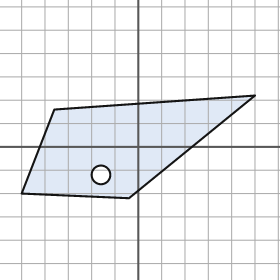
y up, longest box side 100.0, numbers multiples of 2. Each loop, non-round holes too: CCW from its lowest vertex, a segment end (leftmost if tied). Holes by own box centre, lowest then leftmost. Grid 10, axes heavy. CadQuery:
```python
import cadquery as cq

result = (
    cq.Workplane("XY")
    .moveTo(-4.0, -22.0)
    .lineTo(50.0, 22.0)
    .lineTo(-36.0, 16.0)
    .lineTo(-50.0, -20.0)
    .close()
    .moveTo(-16.0, -12.0)
    .circle(4.0)
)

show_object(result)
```